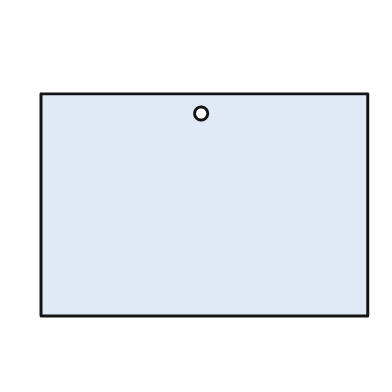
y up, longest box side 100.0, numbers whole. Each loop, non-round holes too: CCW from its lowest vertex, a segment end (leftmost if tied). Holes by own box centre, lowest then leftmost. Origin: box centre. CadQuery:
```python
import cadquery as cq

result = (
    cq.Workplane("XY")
    .moveTo(-50.0, -34.0)
    .lineTo(50.0, -34.0)
    .lineTo(50.0, 34.0)
    .lineTo(-50.0, 34.0)
    .close()
    .moveTo(-1.0, 28.0)
    .circle(2.0)
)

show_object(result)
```